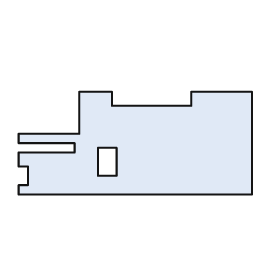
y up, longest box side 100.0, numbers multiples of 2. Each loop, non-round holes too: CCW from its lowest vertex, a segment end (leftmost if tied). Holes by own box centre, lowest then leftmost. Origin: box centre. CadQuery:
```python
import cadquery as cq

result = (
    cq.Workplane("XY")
    .moveTo(-50.0, -22.0)
    .lineTo(50.0, -22.0)
    .lineTo(50.0, 22.0)
    .lineTo(24.0, 22.0)
    .lineTo(24.0, 16.0)
    .lineTo(-10.0, 16.0)
    .lineTo(-10.0, 22.0)
    .lineTo(-24.0, 22.0)
    .lineTo(-24.0, 4.0)
    .lineTo(-50.0, 4.0)
    .lineTo(-50.0, 0.0)
    .lineTo(-26.0, 0.0)
    .lineTo(-26.0, -4.0)
    .lineTo(-50.0, -4.0)
    .lineTo(-50.0, -10.0)
    .lineTo(-46.0, -10.0)
    .lineTo(-46.0, -18.0)
    .lineTo(-50.0, -18.0)
    .close()
    .moveTo(-16.0, -14.0)
    .lineTo(-8.0, -14.0)
    .lineTo(-8.0, -2.0)
    .lineTo(-16.0, -2.0)
    .close()
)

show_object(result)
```